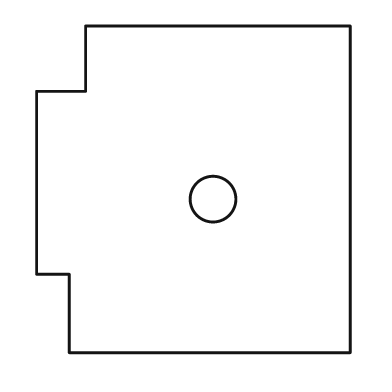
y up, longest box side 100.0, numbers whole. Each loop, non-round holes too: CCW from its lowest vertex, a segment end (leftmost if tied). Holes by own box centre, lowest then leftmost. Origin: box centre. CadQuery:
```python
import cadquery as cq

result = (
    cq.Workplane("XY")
    .moveTo(-38.0, -50.0)
    .lineTo(48.0, -50.0)
    .lineTo(48.0, 50.0)
    .lineTo(-33.0, 50.0)
    .lineTo(-33.0, 30.0)
    .lineTo(-48.0, 30.0)
    .lineTo(-48.0, -26.0)
    .lineTo(-38.0, -26.0)
    .close()
    .moveTo(6.0, -3.0)
    .circle(7.0)
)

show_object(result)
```